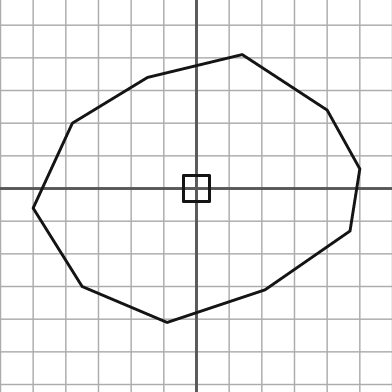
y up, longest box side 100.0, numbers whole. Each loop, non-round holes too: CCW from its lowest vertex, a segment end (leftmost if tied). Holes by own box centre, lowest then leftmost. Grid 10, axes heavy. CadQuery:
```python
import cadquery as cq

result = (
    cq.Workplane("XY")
    .moveTo(-9.0, -41.0)
    .lineTo(21.0, -31.0)
    .lineTo(47.0, -13.0)
    .lineTo(50.0, 6.0)
    .lineTo(40.0, 24.0)
    .lineTo(14.0, 41.0)
    .lineTo(-15.0, 34.0)
    .lineTo(-38.0, 20.0)
    .lineTo(-50.0, -6.0)
    .lineTo(-35.0, -30.0)
    .close()
    .moveTo(-4.0, -4.0)
    .lineTo(4.0, -4.0)
    .lineTo(4.0, 4.0)
    .lineTo(-4.0, 4.0)
    .close()
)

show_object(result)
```